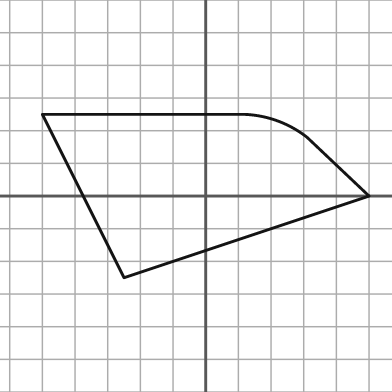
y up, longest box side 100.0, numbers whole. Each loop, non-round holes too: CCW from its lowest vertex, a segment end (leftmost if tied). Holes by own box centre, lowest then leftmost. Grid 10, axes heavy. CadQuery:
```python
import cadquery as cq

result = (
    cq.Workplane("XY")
    .moveTo(-25.0, -25.0)
    .lineTo(50.0, 0.0)
    .lineTo(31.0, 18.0)
    .threePointArc((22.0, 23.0), (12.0, 25.0))
    .lineTo(-50.0, 25.0)
    .close()
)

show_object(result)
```